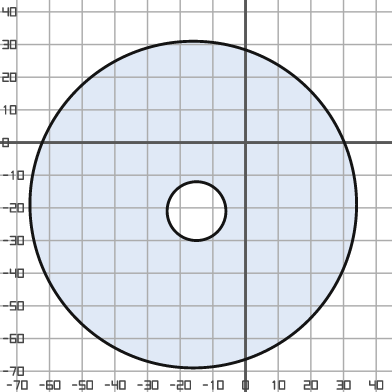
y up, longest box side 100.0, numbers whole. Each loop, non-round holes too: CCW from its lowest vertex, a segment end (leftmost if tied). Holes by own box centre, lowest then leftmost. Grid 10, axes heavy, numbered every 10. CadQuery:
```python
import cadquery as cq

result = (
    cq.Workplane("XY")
    .moveTo(-16.0, -19.0)
    .circle(50.0)
    .moveTo(-15.0, -21.0)
    .circle(9.0)
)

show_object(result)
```